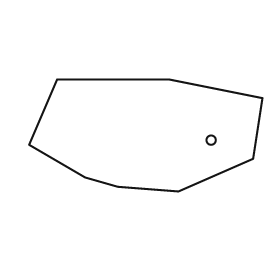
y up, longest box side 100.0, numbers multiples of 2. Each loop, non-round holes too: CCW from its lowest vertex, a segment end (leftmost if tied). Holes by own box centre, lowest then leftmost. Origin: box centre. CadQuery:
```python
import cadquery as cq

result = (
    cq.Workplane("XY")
    .moveTo(14.0, -24.0)
    .lineTo(46.0, -10.0)
    .lineTo(50.0, 16.0)
    .lineTo(10.0, 24.0)
    .lineTo(-38.0, 24.0)
    .lineTo(-50.0, -4.0)
    .lineTo(-26.0, -18.0)
    .lineTo(-12.0, -22.0)
    .close()
    .moveTo(28.0, -2.0)
    .circle(2.0)
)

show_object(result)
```